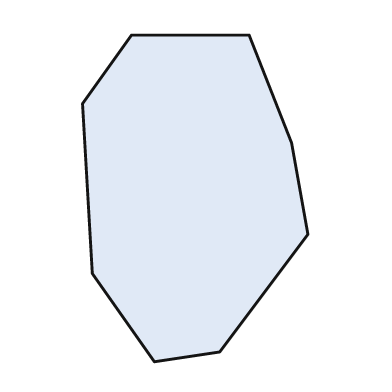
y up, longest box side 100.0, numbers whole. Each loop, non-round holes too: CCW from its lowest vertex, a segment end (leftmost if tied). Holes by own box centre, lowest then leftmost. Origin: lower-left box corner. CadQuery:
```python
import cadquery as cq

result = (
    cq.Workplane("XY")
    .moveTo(22.0, 0.0)
    .lineTo(42.0, 3.0)
    .lineTo(69.0, 39.0)
    .lineTo(64.0, 67.0)
    .lineTo(51.0, 100.0)
    .lineTo(15.0, 100.0)
    .lineTo(0.0, 79.0)
    .lineTo(3.0, 27.0)
    .close()
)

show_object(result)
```